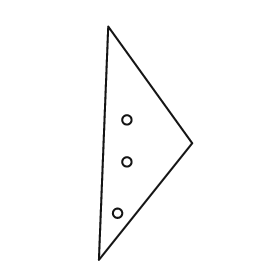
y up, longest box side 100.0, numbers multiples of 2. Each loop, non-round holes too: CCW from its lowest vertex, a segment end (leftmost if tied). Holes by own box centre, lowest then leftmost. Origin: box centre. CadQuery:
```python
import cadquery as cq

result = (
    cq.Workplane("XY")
    .moveTo(-20.0, -50.0)
    .lineTo(20.0, 0.0)
    .lineTo(-16.0, 50.0)
    .close()
    .moveTo(-12.0, -30.0)
    .circle(2.0)
    .moveTo(-8.0, -8.0)
    .circle(2.0)
    .moveTo(-8.0, 10.0)
    .circle(2.0)
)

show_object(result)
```